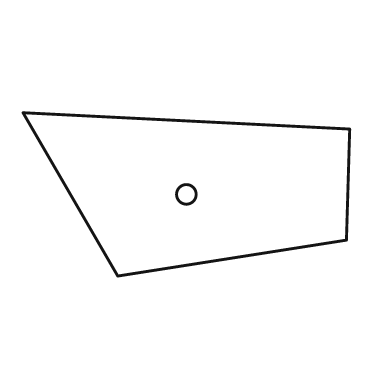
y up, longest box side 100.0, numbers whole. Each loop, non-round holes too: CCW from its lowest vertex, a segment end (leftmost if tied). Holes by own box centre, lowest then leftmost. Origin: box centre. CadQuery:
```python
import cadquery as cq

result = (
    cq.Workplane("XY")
    .moveTo(-21.0, -25.0)
    .lineTo(49.0, -14.0)
    .lineTo(50.0, 20.0)
    .lineTo(-50.0, 25.0)
    .close()
    .moveTo(0.0, 0.0)
    .circle(3.0)
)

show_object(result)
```